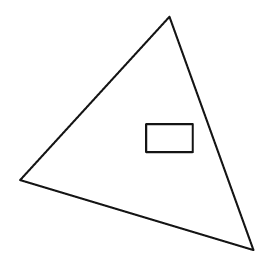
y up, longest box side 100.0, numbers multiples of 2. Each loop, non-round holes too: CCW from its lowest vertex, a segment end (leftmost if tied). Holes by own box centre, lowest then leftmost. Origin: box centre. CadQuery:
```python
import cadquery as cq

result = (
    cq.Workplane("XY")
    .moveTo(50.0, -50.0)
    .lineTo(14.0, 50.0)
    .lineTo(-50.0, -20.0)
    .close()
    .moveTo(4.0, -8.0)
    .lineTo(24.0, -8.0)
    .lineTo(24.0, 4.0)
    .lineTo(4.0, 4.0)
    .close()
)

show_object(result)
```